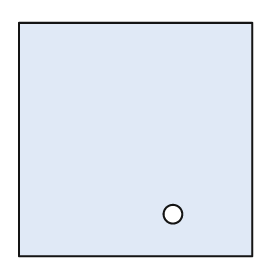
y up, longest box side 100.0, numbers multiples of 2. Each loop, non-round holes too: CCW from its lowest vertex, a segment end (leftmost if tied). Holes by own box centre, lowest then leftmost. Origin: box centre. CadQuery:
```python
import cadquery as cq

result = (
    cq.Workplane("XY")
    .moveTo(-50.0, -50.0)
    .lineTo(50.0, -50.0)
    .lineTo(50.0, 50.0)
    .lineTo(-50.0, 50.0)
    .close()
    .moveTo(16.0, -32.0)
    .circle(4.0)
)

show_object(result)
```